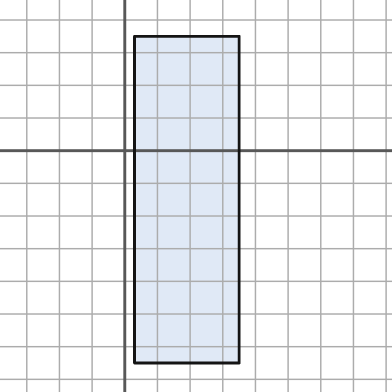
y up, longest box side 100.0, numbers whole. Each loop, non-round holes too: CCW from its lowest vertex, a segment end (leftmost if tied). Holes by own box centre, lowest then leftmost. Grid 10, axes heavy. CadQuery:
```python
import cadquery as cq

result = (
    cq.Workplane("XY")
    .moveTo(3.0, -65.0)
    .lineTo(35.0, -65.0)
    .lineTo(35.0, 35.0)
    .lineTo(3.0, 35.0)
    .close()
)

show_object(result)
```